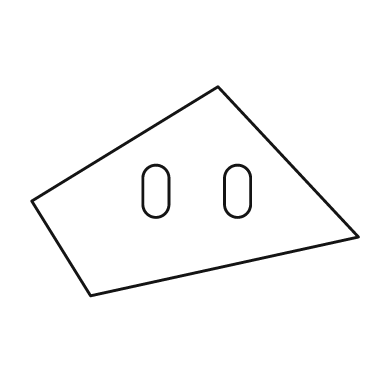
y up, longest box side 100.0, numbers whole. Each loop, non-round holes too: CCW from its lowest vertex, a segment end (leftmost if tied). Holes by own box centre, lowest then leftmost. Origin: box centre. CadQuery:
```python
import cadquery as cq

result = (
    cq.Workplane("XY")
    .moveTo(-32.0, -32.0)
    .lineTo(50.0, -14.0)
    .lineTo(7.0, 32.0)
    .lineTo(-50.0, -3.0)
    .close()
    .moveTo(-16.0, -4.0)
    .threePointArc((-12.0, -8.0), (-8.0, -4.0))
    .lineTo(-8.0, 4.0)
    .threePointArc((-12.0, 8.0), (-16.0, 4.0))
    .close()
    .moveTo(9.0, -4.0)
    .threePointArc((13.0, -8.0), (17.0, -4.0))
    .lineTo(17.0, 4.0)
    .threePointArc((13.0, 8.0), (9.0, 4.0))
    .close()
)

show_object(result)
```